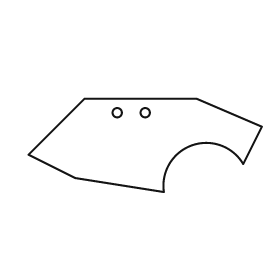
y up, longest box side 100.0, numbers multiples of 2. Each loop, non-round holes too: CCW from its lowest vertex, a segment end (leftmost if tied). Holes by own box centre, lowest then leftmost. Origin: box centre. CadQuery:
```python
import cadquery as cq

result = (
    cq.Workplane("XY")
    .moveTo(8.0, -20.0)
    .threePointArc((20.0, 0.0), (42.0, -8.0))
    .lineTo(50.0, 8.0)
    .lineTo(22.0, 20.0)
    .lineTo(-26.0, 20.0)
    .lineTo(-50.0, -4.0)
    .lineTo(-30.0, -14.0)
    .close()
    .moveTo(-12.0, 14.0)
    .circle(2.0)
    .moveTo(0.0, 14.0)
    .circle(2.0)
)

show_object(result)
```